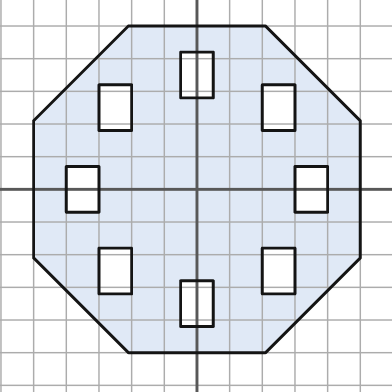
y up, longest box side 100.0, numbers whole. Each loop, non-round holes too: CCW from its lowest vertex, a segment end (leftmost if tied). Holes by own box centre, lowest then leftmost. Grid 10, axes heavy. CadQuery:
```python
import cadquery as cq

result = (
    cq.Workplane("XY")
    .moveTo(-21.0, -50.0)
    .lineTo(21.0, -50.0)
    .lineTo(50.0, -21.0)
    .lineTo(50.0, 21.0)
    .lineTo(21.0, 50.0)
    .lineTo(-21.0, 50.0)
    .lineTo(-50.0, 21.0)
    .lineTo(-50.0, -21.0)
    .close()
    .moveTo(-5.0, -42.0)
    .lineTo(5.0, -42.0)
    .lineTo(5.0, -28.0)
    .lineTo(-5.0, -28.0)
    .close()
    .moveTo(-30.0, -32.0)
    .lineTo(-20.0, -32.0)
    .lineTo(-20.0, -18.0)
    .lineTo(-30.0, -18.0)
    .close()
    .moveTo(20.0, -32.0)
    .lineTo(30.0, -32.0)
    .lineTo(30.0, -18.0)
    .lineTo(20.0, -18.0)
    .close()
    .moveTo(-40.0, -7.0)
    .lineTo(-30.0, -7.0)
    .lineTo(-30.0, 7.0)
    .lineTo(-40.0, 7.0)
    .close()
    .moveTo(30.0, -7.0)
    .lineTo(40.0, -7.0)
    .lineTo(40.0, 7.0)
    .lineTo(30.0, 7.0)
    .close()
    .moveTo(-30.0, 18.0)
    .lineTo(-20.0, 18.0)
    .lineTo(-20.0, 32.0)
    .lineTo(-30.0, 32.0)
    .close()
    .moveTo(20.0, 18.0)
    .lineTo(30.0, 18.0)
    .lineTo(30.0, 32.0)
    .lineTo(20.0, 32.0)
    .close()
    .moveTo(-5.0, 28.0)
    .lineTo(5.0, 28.0)
    .lineTo(5.0, 42.0)
    .lineTo(-5.0, 42.0)
    .close()
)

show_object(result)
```